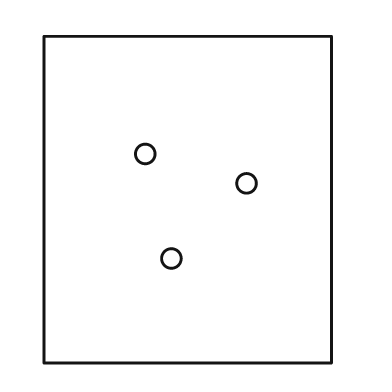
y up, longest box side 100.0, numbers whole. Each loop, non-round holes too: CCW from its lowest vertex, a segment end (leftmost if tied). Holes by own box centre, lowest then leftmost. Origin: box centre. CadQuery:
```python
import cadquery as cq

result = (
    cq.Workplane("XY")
    .moveTo(-44.0, -50.0)
    .lineTo(44.0, -50.0)
    .lineTo(44.0, 50.0)
    .lineTo(-44.0, 50.0)
    .close()
    .moveTo(-5.0, -18.0)
    .circle(3.0)
    .moveTo(18.0, 5.0)
    .circle(3.0)
    .moveTo(-13.0, 14.0)
    .circle(3.0)
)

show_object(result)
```